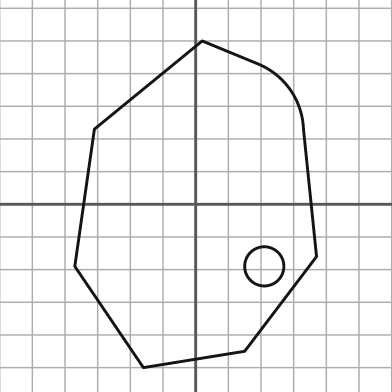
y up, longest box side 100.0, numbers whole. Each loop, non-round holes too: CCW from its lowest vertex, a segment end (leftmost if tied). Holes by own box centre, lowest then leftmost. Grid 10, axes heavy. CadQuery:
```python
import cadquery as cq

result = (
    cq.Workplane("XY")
    .moveTo(-16.0, -50.0)
    .lineTo(15.0, -45.0)
    .lineTo(37.0, -16.0)
    .lineTo(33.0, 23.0)
    .threePointArc((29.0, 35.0), (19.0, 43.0))
    .lineTo(2.0, 50.0)
    .lineTo(-31.0, 23.0)
    .lineTo(-37.0, -19.0)
    .close()
    .moveTo(21.0, -19.0)
    .circle(6.0)
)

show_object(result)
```